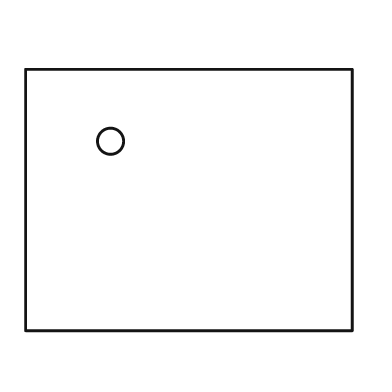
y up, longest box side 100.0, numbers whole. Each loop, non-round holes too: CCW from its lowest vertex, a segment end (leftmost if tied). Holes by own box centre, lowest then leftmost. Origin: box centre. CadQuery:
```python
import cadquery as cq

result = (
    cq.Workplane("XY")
    .moveTo(-50.0, -40.0)
    .lineTo(50.0, -40.0)
    .lineTo(50.0, 40.0)
    .lineTo(-50.0, 40.0)
    .close()
    .moveTo(-24.0, 18.0)
    .circle(4.0)
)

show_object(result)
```